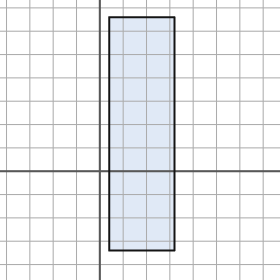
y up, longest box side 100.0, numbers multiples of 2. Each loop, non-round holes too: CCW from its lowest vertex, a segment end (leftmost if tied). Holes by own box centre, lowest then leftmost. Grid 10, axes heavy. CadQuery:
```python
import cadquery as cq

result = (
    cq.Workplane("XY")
    .moveTo(4.0, -34.0)
    .lineTo(32.0, -34.0)
    .lineTo(32.0, 66.0)
    .lineTo(4.0, 66.0)
    .close()
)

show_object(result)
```